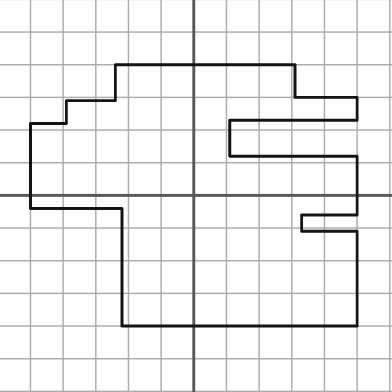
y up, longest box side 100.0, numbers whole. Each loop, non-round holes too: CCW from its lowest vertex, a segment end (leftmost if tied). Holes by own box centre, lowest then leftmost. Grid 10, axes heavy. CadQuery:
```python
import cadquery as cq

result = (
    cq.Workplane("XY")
    .moveTo(-22.0, -40.0)
    .lineTo(50.0, -40.0)
    .lineTo(50.0, -11.0)
    .lineTo(33.0, -11.0)
    .lineTo(33.0, -6.0)
    .lineTo(50.0, -6.0)
    .lineTo(50.0, 12.0)
    .lineTo(11.0, 12.0)
    .lineTo(11.0, 23.0)
    .lineTo(50.0, 23.0)
    .lineTo(50.0, 30.0)
    .lineTo(31.0, 30.0)
    .lineTo(31.0, 40.0)
    .lineTo(-24.0, 40.0)
    .lineTo(-24.0, 29.0)
    .lineTo(-39.0, 29.0)
    .lineTo(-39.0, 22.0)
    .lineTo(-50.0, 22.0)
    .lineTo(-50.0, -4.0)
    .lineTo(-22.0, -4.0)
    .close()
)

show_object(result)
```